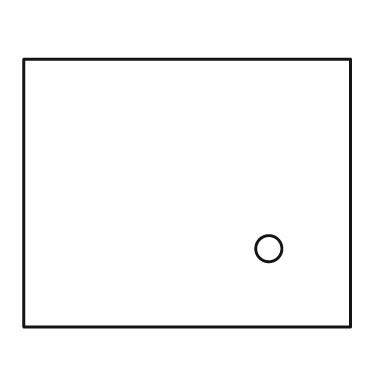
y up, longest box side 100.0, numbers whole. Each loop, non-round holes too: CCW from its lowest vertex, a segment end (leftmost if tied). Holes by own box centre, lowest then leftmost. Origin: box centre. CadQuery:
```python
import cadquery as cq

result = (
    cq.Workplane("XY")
    .moveTo(-50.0, -41.0)
    .lineTo(50.0, -41.0)
    .lineTo(50.0, 41.0)
    .lineTo(-50.0, 41.0)
    .close()
    .moveTo(25.0, -17.0)
    .circle(4.0)
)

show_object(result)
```